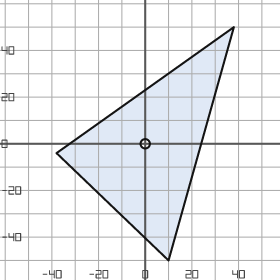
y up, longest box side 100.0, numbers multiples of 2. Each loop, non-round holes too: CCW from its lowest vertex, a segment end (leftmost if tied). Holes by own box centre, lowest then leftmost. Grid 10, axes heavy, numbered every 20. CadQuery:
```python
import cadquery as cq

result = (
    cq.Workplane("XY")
    .moveTo(10.0, -50.0)
    .lineTo(38.0, 50.0)
    .lineTo(-38.0, -4.0)
    .close()
    .moveTo(0.0, 0.0)
    .circle(2.0)
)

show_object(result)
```